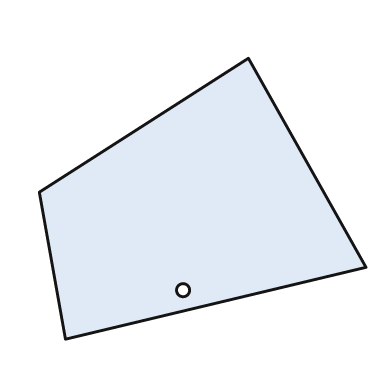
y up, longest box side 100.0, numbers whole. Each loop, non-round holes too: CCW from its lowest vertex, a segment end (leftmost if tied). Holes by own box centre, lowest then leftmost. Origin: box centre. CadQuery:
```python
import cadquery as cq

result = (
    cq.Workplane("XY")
    .moveTo(-42.0, -43.0)
    .lineTo(50.0, -21.0)
    .lineTo(14.0, 43.0)
    .lineTo(-50.0, 2.0)
    .close()
    .moveTo(-6.0, -28.0)
    .circle(2.0)
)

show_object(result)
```